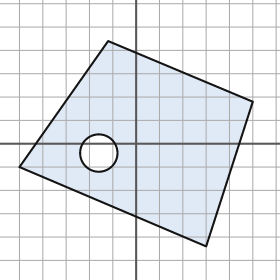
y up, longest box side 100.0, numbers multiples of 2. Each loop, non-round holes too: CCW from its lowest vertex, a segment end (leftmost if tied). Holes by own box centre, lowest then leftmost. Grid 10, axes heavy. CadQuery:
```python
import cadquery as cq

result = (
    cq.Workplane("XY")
    .moveTo(30.0, -44.0)
    .lineTo(50.0, 18.0)
    .lineTo(-12.0, 44.0)
    .lineTo(-50.0, -10.0)
    .close()
    .moveTo(-16.0, -4.0)
    .circle(8.0)
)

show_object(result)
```